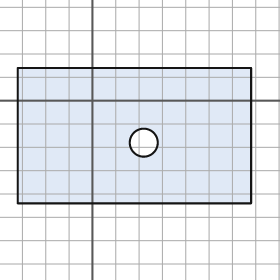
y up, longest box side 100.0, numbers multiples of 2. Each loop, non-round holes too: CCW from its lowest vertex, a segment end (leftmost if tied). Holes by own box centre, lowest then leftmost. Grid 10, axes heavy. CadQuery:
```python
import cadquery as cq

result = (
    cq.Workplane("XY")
    .moveTo(-32.0, -44.0)
    .lineTo(68.0, -44.0)
    .lineTo(68.0, 14.0)
    .lineTo(-32.0, 14.0)
    .close()
    .moveTo(22.0, -18.0)
    .circle(6.0)
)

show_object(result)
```